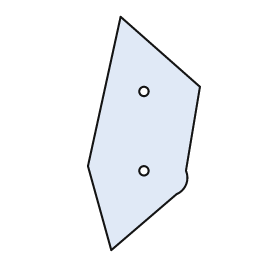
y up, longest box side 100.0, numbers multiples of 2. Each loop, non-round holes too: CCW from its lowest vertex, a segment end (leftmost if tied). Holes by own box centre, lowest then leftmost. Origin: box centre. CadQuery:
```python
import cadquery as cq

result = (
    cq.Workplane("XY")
    .moveTo(-14.0, -50.0)
    .lineTo(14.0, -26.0)
    .threePointArc((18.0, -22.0), (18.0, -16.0))
    .lineTo(24.0, 20.0)
    .lineTo(-10.0, 50.0)
    .lineTo(-24.0, -14.0)
    .close()
    .moveTo(0.0, -16.0)
    .circle(2.0)
    .moveTo(0.0, 18.0)
    .circle(2.0)
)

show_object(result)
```